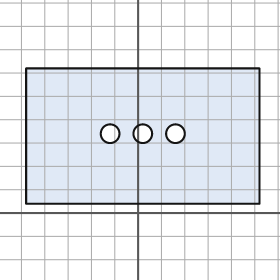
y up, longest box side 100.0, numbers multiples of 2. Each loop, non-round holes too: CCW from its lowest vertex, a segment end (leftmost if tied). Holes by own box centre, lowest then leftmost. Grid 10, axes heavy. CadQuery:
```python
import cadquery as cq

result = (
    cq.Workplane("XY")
    .moveTo(-48.0, 4.0)
    .lineTo(52.0, 4.0)
    .lineTo(52.0, 62.0)
    .lineTo(-48.0, 62.0)
    .close()
    .moveTo(-12.0, 34.0)
    .circle(4.0)
    .moveTo(2.0, 34.0)
    .circle(4.0)
    .moveTo(16.0, 34.0)
    .circle(4.0)
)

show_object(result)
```